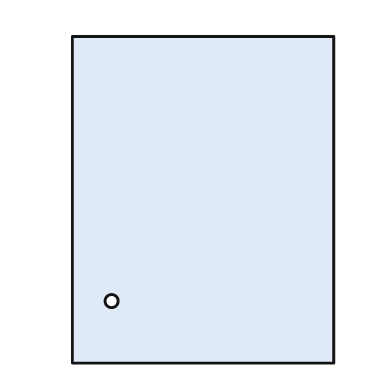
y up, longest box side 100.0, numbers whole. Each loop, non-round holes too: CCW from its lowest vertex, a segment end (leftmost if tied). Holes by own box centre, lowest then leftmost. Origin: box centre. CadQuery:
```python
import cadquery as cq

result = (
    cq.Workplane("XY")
    .moveTo(-40.0, -50.0)
    .lineTo(40.0, -50.0)
    .lineTo(40.0, 50.0)
    .lineTo(-40.0, 50.0)
    .close()
    .moveTo(-28.0, -31.0)
    .circle(2.0)
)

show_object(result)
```